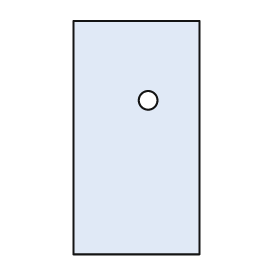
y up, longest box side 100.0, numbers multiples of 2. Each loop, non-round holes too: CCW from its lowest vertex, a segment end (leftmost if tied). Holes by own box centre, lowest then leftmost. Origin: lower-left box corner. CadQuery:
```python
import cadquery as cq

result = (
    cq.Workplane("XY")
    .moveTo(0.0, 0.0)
    .lineTo(54.0, 0.0)
    .lineTo(54.0, 100.0)
    .lineTo(0.0, 100.0)
    .close()
    .moveTo(32.0, 66.0)
    .circle(4.0)
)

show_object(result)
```